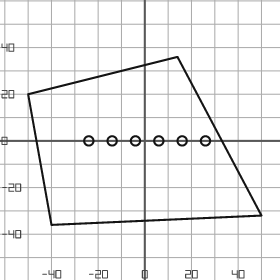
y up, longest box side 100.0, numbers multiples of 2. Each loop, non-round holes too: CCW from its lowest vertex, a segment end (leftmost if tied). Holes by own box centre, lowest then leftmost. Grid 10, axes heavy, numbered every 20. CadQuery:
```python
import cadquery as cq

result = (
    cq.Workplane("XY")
    .moveTo(-40.0, -36.0)
    .lineTo(50.0, -32.0)
    .lineTo(14.0, 36.0)
    .lineTo(-50.0, 20.0)
    .close()
    .moveTo(-24.0, 0.0)
    .circle(2.0)
    .moveTo(-14.0, 0.0)
    .circle(2.0)
    .moveTo(-4.0, 0.0)
    .circle(2.0)
    .moveTo(6.0, 0.0)
    .circle(2.0)
    .moveTo(16.0, 0.0)
    .circle(2.0)
    .moveTo(26.0, 0.0)
    .circle(2.0)
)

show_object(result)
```